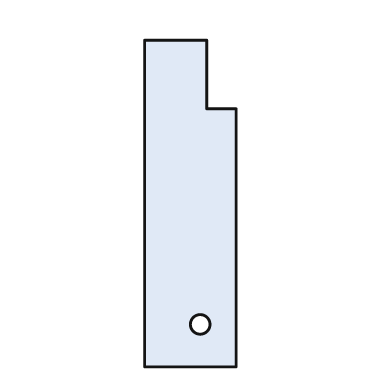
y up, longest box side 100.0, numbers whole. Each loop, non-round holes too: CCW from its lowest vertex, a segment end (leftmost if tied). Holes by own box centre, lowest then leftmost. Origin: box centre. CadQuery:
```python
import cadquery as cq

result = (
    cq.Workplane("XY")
    .moveTo(-14.0, -50.0)
    .lineTo(14.0, -50.0)
    .lineTo(14.0, 29.0)
    .lineTo(5.0, 29.0)
    .lineTo(5.0, 50.0)
    .lineTo(-14.0, 50.0)
    .close()
    .moveTo(3.0, -37.0)
    .circle(3.0)
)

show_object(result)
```